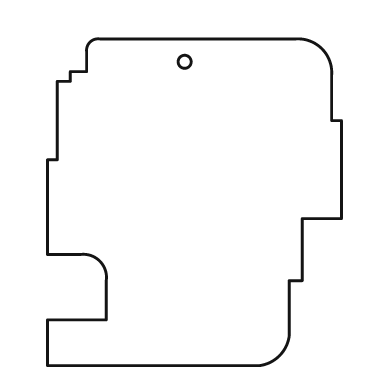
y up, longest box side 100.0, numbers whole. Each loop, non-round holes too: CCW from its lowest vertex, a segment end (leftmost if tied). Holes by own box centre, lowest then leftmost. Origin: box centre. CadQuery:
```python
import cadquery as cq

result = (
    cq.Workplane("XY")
    .moveTo(-45.0, -50.0)
    .lineTo(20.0, -50.0)
    .threePointArc((26.0, -47.0), (29.0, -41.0))
    .lineTo(29.0, -24.0)
    .lineTo(33.0, -24.0)
    .lineTo(33.0, -5.0)
    .lineTo(45.0, -5.0)
    .lineTo(45.0, 25.0)
    .lineTo(42.0, 25.0)
    .lineTo(42.0, 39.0)
    .threePointArc((39.0, 47.0), (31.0, 50.0))
    .lineTo(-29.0, 50.0)
    .threePointArc((-32.0, 49.0), (-33.0, 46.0))
    .lineTo(-33.0, 40.0)
    .lineTo(-38.0, 40.0)
    .lineTo(-38.0, 37.0)
    .lineTo(-42.0, 37.0)
    .lineTo(-42.0, 13.0)
    .lineTo(-45.0, 13.0)
    .lineTo(-45.0, -16.0)
    .lineTo(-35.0, -16.0)
    .threePointArc((-29.0, -18.0), (-27.0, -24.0))
    .lineTo(-27.0, -36.0)
    .lineTo(-45.0, -36.0)
    .close()
    .moveTo(-3.0, 43.0)
    .circle(2.0)
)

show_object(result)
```